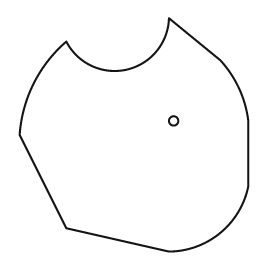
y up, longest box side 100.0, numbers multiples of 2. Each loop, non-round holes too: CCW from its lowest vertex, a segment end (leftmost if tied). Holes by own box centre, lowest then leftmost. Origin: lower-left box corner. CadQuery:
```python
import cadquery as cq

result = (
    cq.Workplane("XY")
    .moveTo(64.0, 0.0)
    .threePointArc((86.0, 8.0), (98.0, 28.0))
    .lineTo(98.0, 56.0)
    .threePointArc((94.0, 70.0), (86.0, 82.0))
    .lineTo(64.0, 100.0)
    .threePointArc((46.0, 78.0), (20.0, 90.0))
    .threePointArc((6.0, 72.0), (0.0, 50.0))
    .lineTo(20.0, 10.0)
    .close()
    .moveTo(66.0, 56.0)
    .circle(2.0)
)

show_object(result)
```